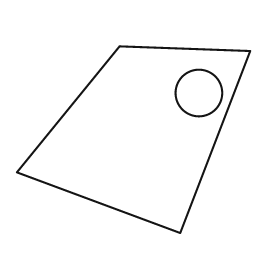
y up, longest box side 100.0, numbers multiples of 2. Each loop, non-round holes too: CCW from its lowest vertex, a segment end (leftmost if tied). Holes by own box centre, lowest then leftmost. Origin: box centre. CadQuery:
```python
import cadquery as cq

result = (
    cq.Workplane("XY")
    .moveTo(20.0, -40.0)
    .lineTo(50.0, 38.0)
    .lineTo(-6.0, 40.0)
    .lineTo(-50.0, -14.0)
    .close()
    .moveTo(28.0, 20.0)
    .circle(10.0)
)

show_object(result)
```